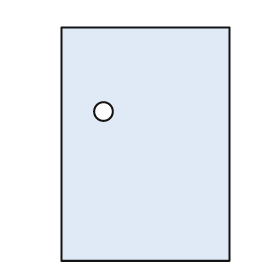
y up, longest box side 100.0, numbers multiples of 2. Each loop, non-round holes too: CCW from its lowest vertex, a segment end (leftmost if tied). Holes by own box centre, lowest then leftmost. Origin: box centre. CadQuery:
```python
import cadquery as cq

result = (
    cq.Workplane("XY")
    .moveTo(-36.0, -50.0)
    .lineTo(36.0, -50.0)
    .lineTo(36.0, 50.0)
    .lineTo(-36.0, 50.0)
    .close()
    .moveTo(-18.0, 14.0)
    .circle(4.0)
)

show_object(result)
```